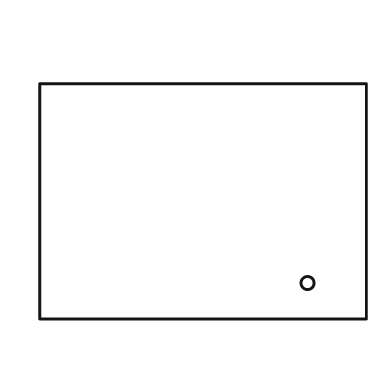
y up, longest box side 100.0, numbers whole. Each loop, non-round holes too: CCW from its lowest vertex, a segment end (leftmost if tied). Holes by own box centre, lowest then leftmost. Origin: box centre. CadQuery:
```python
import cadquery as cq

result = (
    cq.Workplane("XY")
    .moveTo(-50.0, -36.0)
    .lineTo(50.0, -36.0)
    .lineTo(50.0, 36.0)
    .lineTo(-50.0, 36.0)
    .close()
    .moveTo(32.0, -25.0)
    .circle(2.0)
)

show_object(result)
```